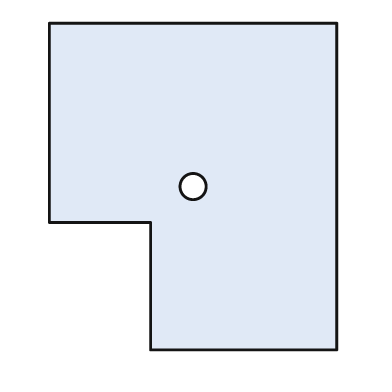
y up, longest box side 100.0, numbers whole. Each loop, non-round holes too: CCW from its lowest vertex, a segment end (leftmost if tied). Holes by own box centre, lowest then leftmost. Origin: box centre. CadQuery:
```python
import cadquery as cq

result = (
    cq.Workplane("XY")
    .moveTo(-13.0, -50.0)
    .lineTo(44.0, -50.0)
    .lineTo(44.0, 50.0)
    .lineTo(-44.0, 50.0)
    .lineTo(-44.0, -11.0)
    .lineTo(-13.0, -11.0)
    .close()
    .moveTo(0.0, 0.0)
    .circle(4.0)
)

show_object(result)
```